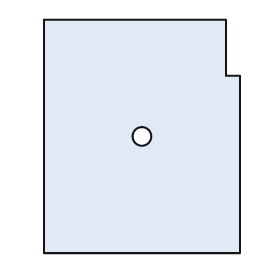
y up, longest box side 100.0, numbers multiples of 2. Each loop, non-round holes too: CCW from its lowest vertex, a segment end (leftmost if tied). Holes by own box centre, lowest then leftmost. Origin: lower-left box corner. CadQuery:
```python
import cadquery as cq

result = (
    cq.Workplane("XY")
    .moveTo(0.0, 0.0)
    .lineTo(84.0, 0.0)
    .lineTo(84.0, 76.0)
    .lineTo(78.0, 76.0)
    .lineTo(78.0, 100.0)
    .lineTo(0.0, 100.0)
    .close()
    .moveTo(42.0, 50.0)
    .circle(4.0)
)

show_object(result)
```